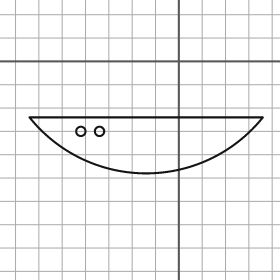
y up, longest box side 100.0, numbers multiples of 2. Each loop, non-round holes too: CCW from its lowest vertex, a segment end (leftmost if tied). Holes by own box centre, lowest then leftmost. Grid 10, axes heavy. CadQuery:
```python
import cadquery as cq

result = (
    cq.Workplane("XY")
    .moveTo(-64.0, -24.0)
    .threePointArc((-14.0, -48.0), (36.0, -24.0))
    .close()
    .moveTo(-42.0, -30.0)
    .circle(2.0)
    .moveTo(-34.0, -30.0)
    .circle(2.0)
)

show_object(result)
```